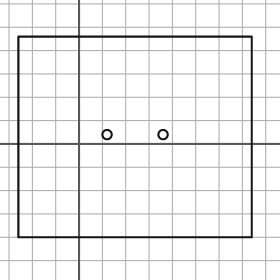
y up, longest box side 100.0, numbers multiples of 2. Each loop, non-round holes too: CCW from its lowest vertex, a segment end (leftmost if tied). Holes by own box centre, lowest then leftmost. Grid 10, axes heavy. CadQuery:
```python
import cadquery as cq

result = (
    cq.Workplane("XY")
    .moveTo(-26.0, -40.0)
    .lineTo(74.0, -40.0)
    .lineTo(74.0, 46.0)
    .lineTo(-26.0, 46.0)
    .close()
    .moveTo(12.0, 4.0)
    .circle(2.0)
    .moveTo(36.0, 4.0)
    .circle(2.0)
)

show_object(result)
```